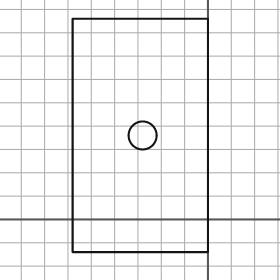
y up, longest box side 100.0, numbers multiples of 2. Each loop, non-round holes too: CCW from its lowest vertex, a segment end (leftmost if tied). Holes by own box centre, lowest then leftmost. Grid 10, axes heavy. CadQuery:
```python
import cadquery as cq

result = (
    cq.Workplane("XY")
    .moveTo(-58.0, -14.0)
    .lineTo(0.0, -14.0)
    .lineTo(0.0, 86.0)
    .lineTo(-58.0, 86.0)
    .close()
    .moveTo(-28.0, 36.0)
    .circle(6.0)
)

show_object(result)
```